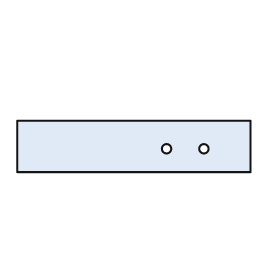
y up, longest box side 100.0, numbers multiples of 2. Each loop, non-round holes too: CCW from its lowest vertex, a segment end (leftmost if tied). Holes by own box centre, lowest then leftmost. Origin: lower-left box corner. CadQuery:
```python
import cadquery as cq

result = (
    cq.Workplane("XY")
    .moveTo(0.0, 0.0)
    .lineTo(100.0, 0.0)
    .lineTo(100.0, 22.0)
    .lineTo(0.0, 22.0)
    .close()
    .moveTo(64.0, 10.0)
    .circle(2.0)
    .moveTo(80.0, 10.0)
    .circle(2.0)
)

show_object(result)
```